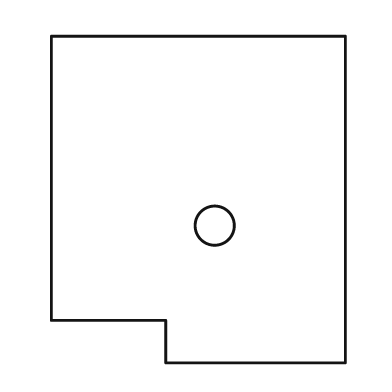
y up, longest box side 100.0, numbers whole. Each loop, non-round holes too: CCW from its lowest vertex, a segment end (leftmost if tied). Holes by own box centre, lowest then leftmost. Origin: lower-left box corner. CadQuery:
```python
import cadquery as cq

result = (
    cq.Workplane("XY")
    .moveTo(35.0, 0.0)
    .lineTo(90.0, 0.0)
    .lineTo(90.0, 100.0)
    .lineTo(0.0, 100.0)
    .lineTo(0.0, 13.0)
    .lineTo(35.0, 13.0)
    .close()
    .moveTo(50.0, 42.0)
    .circle(6.0)
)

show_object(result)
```